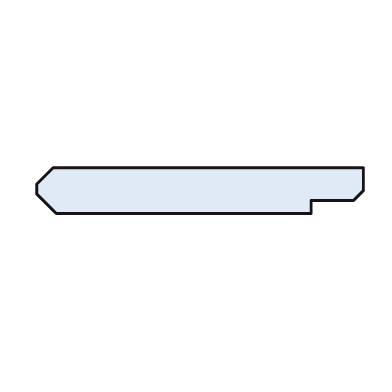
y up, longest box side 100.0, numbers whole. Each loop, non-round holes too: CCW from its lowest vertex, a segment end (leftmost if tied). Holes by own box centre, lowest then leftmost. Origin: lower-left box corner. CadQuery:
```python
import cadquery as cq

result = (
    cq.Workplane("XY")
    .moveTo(6.0, 0.0)
    .lineTo(84.0, 0.0)
    .lineTo(84.0, 4.0)
    .lineTo(97.0, 4.0)
    .lineTo(100.0, 7.0)
    .lineTo(100.0, 14.0)
    .lineTo(5.0, 14.0)
    .lineTo(0.0, 9.0)
    .lineTo(0.0, 6.0)
    .close()
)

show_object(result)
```